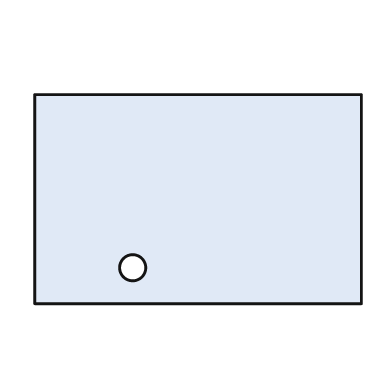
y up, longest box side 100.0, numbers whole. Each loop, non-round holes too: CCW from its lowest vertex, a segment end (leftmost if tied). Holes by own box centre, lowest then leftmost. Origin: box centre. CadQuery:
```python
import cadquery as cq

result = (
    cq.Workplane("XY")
    .moveTo(-50.0, -32.0)
    .lineTo(50.0, -32.0)
    .lineTo(50.0, 32.0)
    .lineTo(-50.0, 32.0)
    .close()
    .moveTo(-20.0, -21.0)
    .circle(4.0)
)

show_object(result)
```